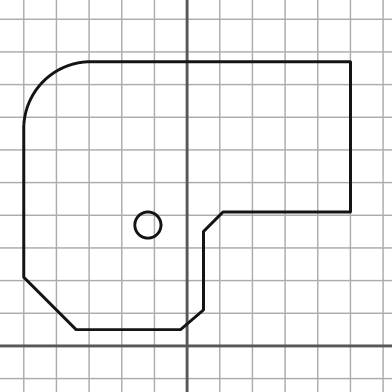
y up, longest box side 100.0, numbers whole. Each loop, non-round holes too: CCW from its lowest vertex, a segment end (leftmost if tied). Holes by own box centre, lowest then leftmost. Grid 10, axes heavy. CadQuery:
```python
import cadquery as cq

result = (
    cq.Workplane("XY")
    .moveTo(-34.0, 5.0)
    .lineTo(-2.0, 5.0)
    .lineTo(5.0, 11.0)
    .lineTo(5.0, 35.0)
    .lineTo(11.0, 41.0)
    .lineTo(50.0, 41.0)
    .lineTo(50.0, 87.0)
    .lineTo(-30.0, 87.0)
    .threePointArc((-44.0, 81.0), (-50.0, 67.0))
    .lineTo(-50.0, 21.0)
    .close()
    .moveTo(-12.0, 37.0)
    .circle(4.0)
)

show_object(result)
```